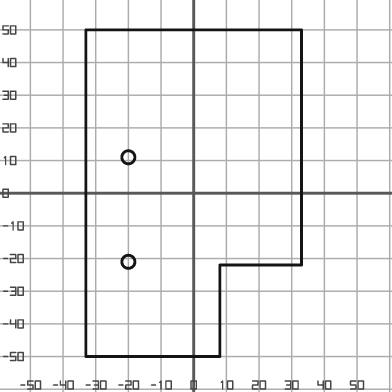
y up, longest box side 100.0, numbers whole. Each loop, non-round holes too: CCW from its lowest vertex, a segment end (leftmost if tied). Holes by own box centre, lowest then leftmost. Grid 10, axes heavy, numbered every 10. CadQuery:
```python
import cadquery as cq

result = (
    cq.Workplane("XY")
    .moveTo(-33.0, -50.0)
    .lineTo(8.0, -50.0)
    .lineTo(8.0, -22.0)
    .lineTo(33.0, -22.0)
    .lineTo(33.0, 50.0)
    .lineTo(-33.0, 50.0)
    .close()
    .moveTo(-20.0, -21.0)
    .circle(2.0)
    .moveTo(-20.0, 11.0)
    .circle(2.0)
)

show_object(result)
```